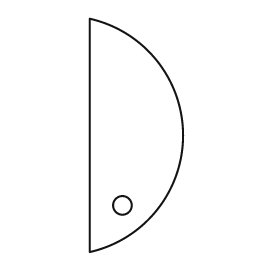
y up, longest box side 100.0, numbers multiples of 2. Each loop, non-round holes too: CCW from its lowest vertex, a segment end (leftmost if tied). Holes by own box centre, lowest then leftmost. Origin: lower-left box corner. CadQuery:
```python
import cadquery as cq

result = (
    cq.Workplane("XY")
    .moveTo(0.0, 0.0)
    .threePointArc((40.0, 50.0), (0.0, 100.0))
    .close()
    .moveTo(14.0, 20.0)
    .circle(4.0)
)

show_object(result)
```